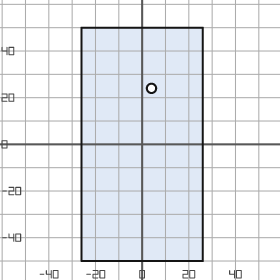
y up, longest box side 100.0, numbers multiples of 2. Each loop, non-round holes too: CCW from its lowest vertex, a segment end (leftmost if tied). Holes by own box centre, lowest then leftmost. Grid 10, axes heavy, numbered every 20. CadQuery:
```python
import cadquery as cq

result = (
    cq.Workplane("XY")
    .moveTo(-26.0, -50.0)
    .lineTo(26.0, -50.0)
    .lineTo(26.0, 50.0)
    .lineTo(-26.0, 50.0)
    .close()
    .moveTo(4.0, 24.0)
    .circle(2.0)
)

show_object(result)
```